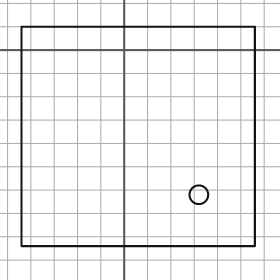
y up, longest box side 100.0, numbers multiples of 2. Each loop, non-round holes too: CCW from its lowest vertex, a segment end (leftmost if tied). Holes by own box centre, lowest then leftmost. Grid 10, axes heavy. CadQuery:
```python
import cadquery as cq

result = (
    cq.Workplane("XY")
    .moveTo(-44.0, -84.0)
    .lineTo(56.0, -84.0)
    .lineTo(56.0, 10.0)
    .lineTo(-44.0, 10.0)
    .close()
    .moveTo(32.0, -62.0)
    .circle(4.0)
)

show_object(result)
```